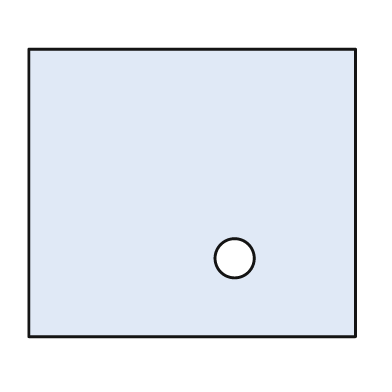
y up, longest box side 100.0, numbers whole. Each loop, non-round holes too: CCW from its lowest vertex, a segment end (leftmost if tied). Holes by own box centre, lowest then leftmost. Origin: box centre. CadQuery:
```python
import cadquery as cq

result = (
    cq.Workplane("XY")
    .moveTo(-50.0, -44.0)
    .lineTo(50.0, -44.0)
    .lineTo(50.0, 44.0)
    .lineTo(-50.0, 44.0)
    .close()
    .moveTo(13.0, -20.0)
    .circle(6.0)
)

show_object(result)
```